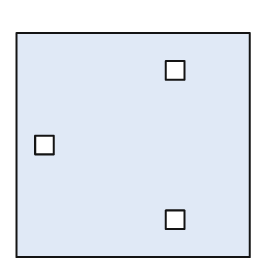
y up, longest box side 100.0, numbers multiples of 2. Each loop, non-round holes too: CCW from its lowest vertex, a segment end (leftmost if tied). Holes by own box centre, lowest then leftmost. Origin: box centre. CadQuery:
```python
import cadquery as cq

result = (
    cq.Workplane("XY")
    .moveTo(-50.0, -48.0)
    .lineTo(50.0, -48.0)
    .lineTo(50.0, 48.0)
    .lineTo(-50.0, 48.0)
    .close()
    .moveTo(14.0, -36.0)
    .lineTo(22.0, -36.0)
    .lineTo(22.0, -28.0)
    .lineTo(14.0, -28.0)
    .close()
    .moveTo(-42.0, -4.0)
    .lineTo(-34.0, -4.0)
    .lineTo(-34.0, 4.0)
    .lineTo(-42.0, 4.0)
    .close()
    .moveTo(14.0, 28.0)
    .lineTo(22.0, 28.0)
    .lineTo(22.0, 36.0)
    .lineTo(14.0, 36.0)
    .close()
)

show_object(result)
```